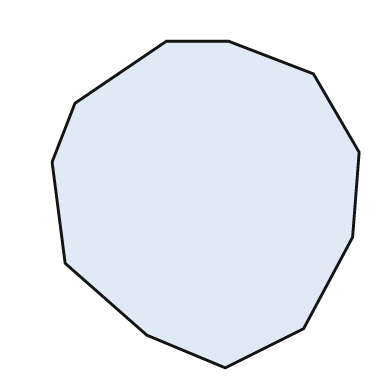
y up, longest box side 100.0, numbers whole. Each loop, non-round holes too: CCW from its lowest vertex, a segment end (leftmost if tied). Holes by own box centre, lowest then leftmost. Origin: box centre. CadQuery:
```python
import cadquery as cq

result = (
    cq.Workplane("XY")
    .moveTo(6.0, -50.0)
    .lineTo(30.0, -38.0)
    .lineTo(45.0, -10.0)
    .lineTo(47.0, 16.0)
    .lineTo(33.0, 40.0)
    .lineTo(7.0, 50.0)
    .lineTo(-12.0, 50.0)
    .lineTo(-40.0, 31.0)
    .lineTo(-47.0, 13.0)
    .lineTo(-43.0, -18.0)
    .lineTo(-18.0, -40.0)
    .close()
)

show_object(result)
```